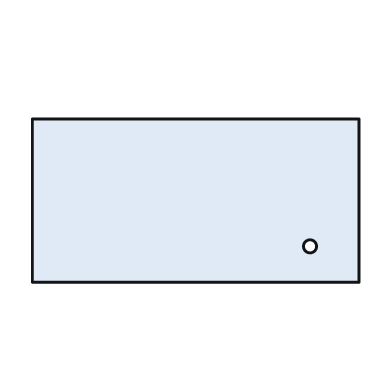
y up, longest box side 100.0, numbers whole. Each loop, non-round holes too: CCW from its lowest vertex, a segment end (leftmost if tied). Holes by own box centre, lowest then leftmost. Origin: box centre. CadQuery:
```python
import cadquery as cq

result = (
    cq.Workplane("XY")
    .moveTo(-50.0, -25.0)
    .lineTo(50.0, -25.0)
    .lineTo(50.0, 25.0)
    .lineTo(-50.0, 25.0)
    .close()
    .moveTo(35.0, -14.0)
    .circle(2.0)
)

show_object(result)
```